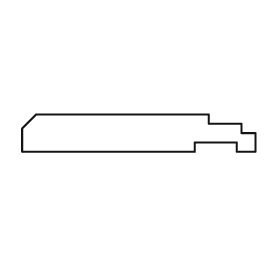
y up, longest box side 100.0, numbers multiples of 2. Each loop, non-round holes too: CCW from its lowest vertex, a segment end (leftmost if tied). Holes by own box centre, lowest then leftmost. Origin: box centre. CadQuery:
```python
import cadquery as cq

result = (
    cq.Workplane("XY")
    .moveTo(-50.0, -8.0)
    .lineTo(24.0, -8.0)
    .lineTo(24.0, -4.0)
    .lineTo(42.0, -4.0)
    .lineTo(42.0, -8.0)
    .lineTo(50.0, -8.0)
    .lineTo(50.0, 0.0)
    .lineTo(44.0, 0.0)
    .lineTo(44.0, 4.0)
    .lineTo(30.0, 4.0)
    .lineTo(30.0, 8.0)
    .lineTo(-44.0, 8.0)
    .lineTo(-50.0, 2.0)
    .close()
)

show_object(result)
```